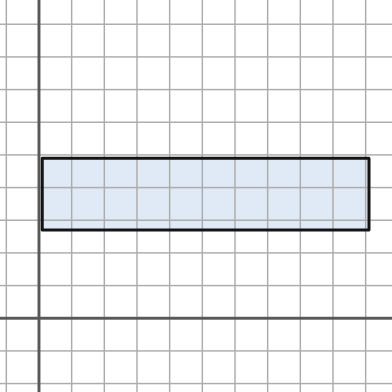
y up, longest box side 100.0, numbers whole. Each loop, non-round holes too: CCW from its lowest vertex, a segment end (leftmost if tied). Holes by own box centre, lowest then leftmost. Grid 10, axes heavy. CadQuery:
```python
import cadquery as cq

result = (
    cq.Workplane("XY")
    .moveTo(1.0, 27.0)
    .lineTo(101.0, 27.0)
    .lineTo(101.0, 49.0)
    .lineTo(1.0, 49.0)
    .close()
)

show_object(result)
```